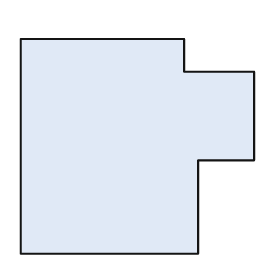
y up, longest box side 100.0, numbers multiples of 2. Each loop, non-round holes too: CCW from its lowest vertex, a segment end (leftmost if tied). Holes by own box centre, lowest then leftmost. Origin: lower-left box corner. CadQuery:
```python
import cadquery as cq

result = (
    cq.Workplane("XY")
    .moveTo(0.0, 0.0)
    .lineTo(76.0, 0.0)
    .lineTo(76.0, 40.0)
    .lineTo(100.0, 40.0)
    .lineTo(100.0, 78.0)
    .lineTo(70.0, 78.0)
    .lineTo(70.0, 92.0)
    .lineTo(0.0, 92.0)
    .close()
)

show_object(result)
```